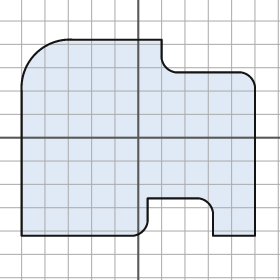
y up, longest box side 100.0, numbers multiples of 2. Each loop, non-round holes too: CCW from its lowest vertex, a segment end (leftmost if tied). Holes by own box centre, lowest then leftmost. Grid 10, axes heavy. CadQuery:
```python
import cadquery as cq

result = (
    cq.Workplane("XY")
    .moveTo(-50.0, -42.0)
    .lineTo(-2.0, -42.0)
    .threePointArc((2.0, -40.0), (4.0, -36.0))
    .lineTo(4.0, -26.0)
    .lineTo(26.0, -26.0)
    .threePointArc((30.0, -28.0), (32.0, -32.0))
    .lineTo(32.0, -42.0)
    .lineTo(50.0, -42.0)
    .lineTo(50.0, 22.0)
    .threePointArc((48.0, 26.0), (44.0, 28.0))
    .lineTo(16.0, 28.0)
    .threePointArc((12.0, 30.0), (10.0, 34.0))
    .lineTo(10.0, 42.0)
    .lineTo(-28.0, 42.0)
    .threePointArc((-44.0, 36.0), (-50.0, 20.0))
    .close()
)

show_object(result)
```